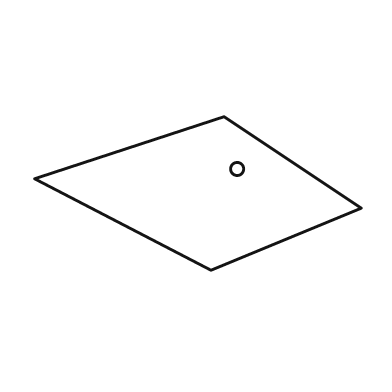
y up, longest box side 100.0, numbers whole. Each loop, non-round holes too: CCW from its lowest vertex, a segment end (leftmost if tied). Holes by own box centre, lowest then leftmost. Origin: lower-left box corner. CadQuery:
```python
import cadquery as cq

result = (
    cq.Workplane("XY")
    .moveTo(54.0, 0.0)
    .lineTo(100.0, 19.0)
    .lineTo(58.0, 47.0)
    .lineTo(0.0, 28.0)
    .close()
    .moveTo(62.0, 31.0)
    .circle(2.0)
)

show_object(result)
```